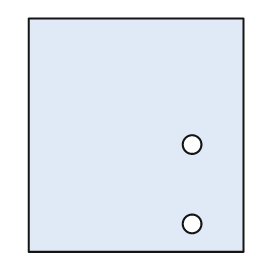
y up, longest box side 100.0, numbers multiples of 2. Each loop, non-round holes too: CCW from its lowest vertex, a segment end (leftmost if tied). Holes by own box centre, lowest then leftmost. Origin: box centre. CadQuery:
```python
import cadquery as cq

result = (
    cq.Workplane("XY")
    .moveTo(-46.0, -50.0)
    .lineTo(46.0, -50.0)
    .lineTo(46.0, 50.0)
    .lineTo(-46.0, 50.0)
    .close()
    .moveTo(24.0, -38.0)
    .circle(4.0)
    .moveTo(24.0, -4.0)
    .circle(4.0)
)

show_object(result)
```